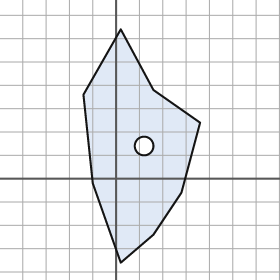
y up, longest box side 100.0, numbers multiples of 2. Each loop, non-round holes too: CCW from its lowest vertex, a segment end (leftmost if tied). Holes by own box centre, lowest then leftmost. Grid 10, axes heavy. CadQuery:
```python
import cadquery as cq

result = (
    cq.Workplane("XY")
    .moveTo(2.0, -36.0)
    .lineTo(16.0, -24.0)
    .lineTo(28.0, -6.0)
    .lineTo(36.0, 24.0)
    .lineTo(16.0, 38.0)
    .lineTo(2.0, 64.0)
    .lineTo(-14.0, 36.0)
    .lineTo(-10.0, -2.0)
    .close()
    .moveTo(12.0, 14.0)
    .circle(4.0)
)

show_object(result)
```